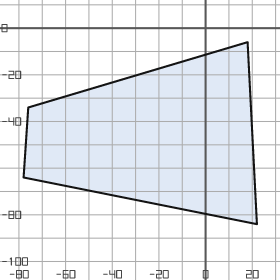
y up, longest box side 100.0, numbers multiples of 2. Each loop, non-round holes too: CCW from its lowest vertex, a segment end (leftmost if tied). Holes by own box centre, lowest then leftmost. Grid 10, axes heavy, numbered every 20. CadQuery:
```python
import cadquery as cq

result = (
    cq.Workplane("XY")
    .moveTo(22.0, -84.0)
    .lineTo(18.0, -6.0)
    .lineTo(-76.0, -34.0)
    .lineTo(-78.0, -64.0)
    .close()
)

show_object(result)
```